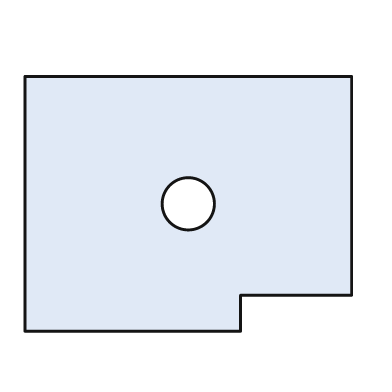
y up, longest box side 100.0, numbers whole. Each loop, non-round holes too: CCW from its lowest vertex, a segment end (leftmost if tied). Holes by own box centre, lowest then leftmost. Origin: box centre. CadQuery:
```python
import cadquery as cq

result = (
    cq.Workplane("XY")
    .moveTo(-50.0, -39.0)
    .lineTo(16.0, -39.0)
    .lineTo(16.0, -28.0)
    .lineTo(50.0, -28.0)
    .lineTo(50.0, 39.0)
    .lineTo(-50.0, 39.0)
    .close()
    .moveTo(0.0, 0.0)
    .circle(8.0)
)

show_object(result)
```